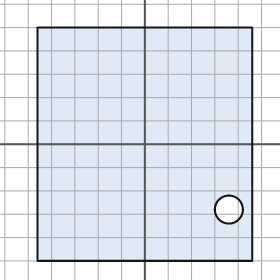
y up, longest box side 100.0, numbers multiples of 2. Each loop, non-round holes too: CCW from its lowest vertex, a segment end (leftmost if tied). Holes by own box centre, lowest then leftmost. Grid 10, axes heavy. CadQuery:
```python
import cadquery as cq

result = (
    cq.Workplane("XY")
    .moveTo(-46.0, -50.0)
    .lineTo(46.0, -50.0)
    .lineTo(46.0, 50.0)
    .lineTo(-46.0, 50.0)
    .close()
    .moveTo(36.0, -28.0)
    .circle(6.0)
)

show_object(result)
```